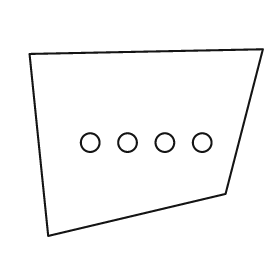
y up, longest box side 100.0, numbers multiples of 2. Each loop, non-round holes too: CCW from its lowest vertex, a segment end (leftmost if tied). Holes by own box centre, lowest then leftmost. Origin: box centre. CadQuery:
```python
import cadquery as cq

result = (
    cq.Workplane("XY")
    .moveTo(-42.0, -40.0)
    .lineTo(34.0, -22.0)
    .lineTo(50.0, 40.0)
    .lineTo(-50.0, 38.0)
    .close()
    .moveTo(-24.0, 0.0)
    .circle(4.0)
    .moveTo(-8.0, 0.0)
    .circle(4.0)
    .moveTo(8.0, 0.0)
    .circle(4.0)
    .moveTo(24.0, 0.0)
    .circle(4.0)
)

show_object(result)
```